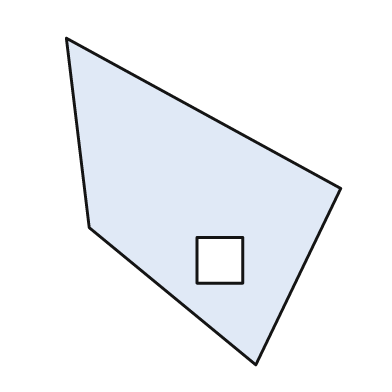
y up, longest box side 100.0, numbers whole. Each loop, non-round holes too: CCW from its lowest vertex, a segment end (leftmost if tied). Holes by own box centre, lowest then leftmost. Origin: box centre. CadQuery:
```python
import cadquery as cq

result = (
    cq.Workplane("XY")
    .moveTo(16.0, -50.0)
    .lineTo(42.0, 4.0)
    .lineTo(-42.0, 50.0)
    .lineTo(-35.0, -8.0)
    .close()
    .moveTo(-2.0, -25.0)
    .lineTo(12.0, -25.0)
    .lineTo(12.0, -11.0)
    .lineTo(-2.0, -11.0)
    .close()
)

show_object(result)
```